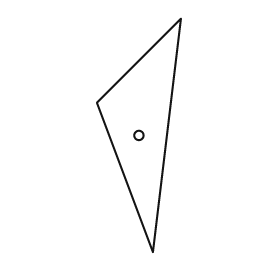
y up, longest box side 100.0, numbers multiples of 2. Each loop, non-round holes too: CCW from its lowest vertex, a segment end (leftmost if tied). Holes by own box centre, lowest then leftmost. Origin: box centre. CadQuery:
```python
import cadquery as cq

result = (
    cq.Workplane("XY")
    .moveTo(6.0, -50.0)
    .lineTo(18.0, 50.0)
    .lineTo(-18.0, 14.0)
    .close()
    .moveTo(0.0, 0.0)
    .circle(2.0)
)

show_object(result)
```